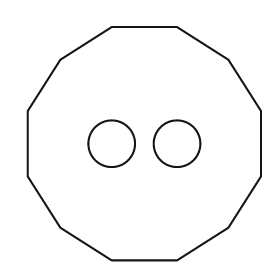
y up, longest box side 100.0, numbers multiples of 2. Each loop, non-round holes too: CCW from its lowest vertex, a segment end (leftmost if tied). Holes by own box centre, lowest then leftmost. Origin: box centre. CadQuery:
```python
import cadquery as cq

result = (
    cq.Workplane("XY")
    .moveTo(-14.0, -50.0)
    .lineTo(14.0, -50.0)
    .lineTo(36.0, -36.0)
    .lineTo(50.0, -14.0)
    .lineTo(50.0, 14.0)
    .lineTo(36.0, 36.0)
    .lineTo(14.0, 50.0)
    .lineTo(-14.0, 50.0)
    .lineTo(-36.0, 36.0)
    .lineTo(-50.0, 14.0)
    .lineTo(-50.0, -14.0)
    .lineTo(-36.0, -36.0)
    .close()
    .moveTo(-14.0, 0.0)
    .circle(10.0)
    .moveTo(14.0, 0.0)
    .circle(10.0)
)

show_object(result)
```